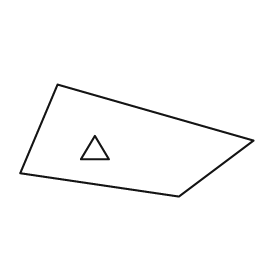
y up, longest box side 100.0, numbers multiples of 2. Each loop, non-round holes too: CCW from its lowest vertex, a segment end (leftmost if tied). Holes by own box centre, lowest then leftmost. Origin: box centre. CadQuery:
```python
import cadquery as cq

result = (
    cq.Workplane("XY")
    .moveTo(18.0, -24.0)
    .lineTo(50.0, 0.0)
    .lineTo(-34.0, 24.0)
    .lineTo(-50.0, -14.0)
    .close()
    .moveTo(-24.0, -8.0)
    .lineTo(-12.0, -8.0)
    .lineTo(-18.0, 2.0)
    .close()
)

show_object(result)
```